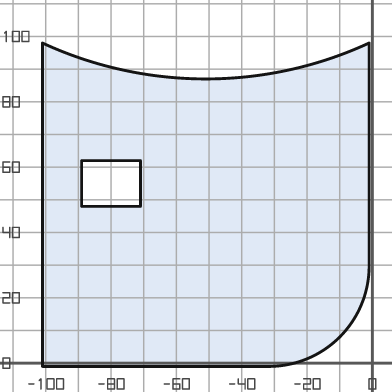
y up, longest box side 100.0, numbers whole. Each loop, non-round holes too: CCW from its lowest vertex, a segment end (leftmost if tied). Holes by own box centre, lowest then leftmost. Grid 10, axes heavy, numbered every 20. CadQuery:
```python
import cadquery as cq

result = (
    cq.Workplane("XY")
    .moveTo(-101.0, -1.0)
    .lineTo(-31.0, -1.0)
    .threePointArc((-10.0, 8.0), (-1.0, 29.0))
    .lineTo(-1.0, 98.0)
    .threePointArc((-51.0, 87.0), (-101.0, 98.0))
    .close()
    .moveTo(-89.0, 48.0)
    .lineTo(-71.0, 48.0)
    .lineTo(-71.0, 62.0)
    .lineTo(-89.0, 62.0)
    .close()
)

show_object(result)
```